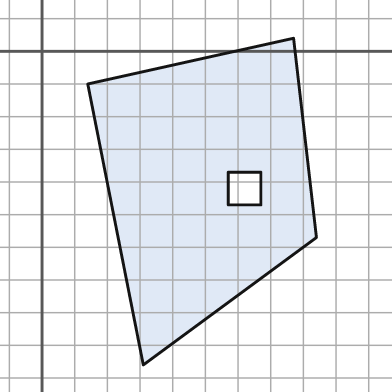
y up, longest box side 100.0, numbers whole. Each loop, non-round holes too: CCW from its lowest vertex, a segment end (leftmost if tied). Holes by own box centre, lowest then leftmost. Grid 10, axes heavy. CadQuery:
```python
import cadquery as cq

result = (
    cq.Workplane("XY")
    .moveTo(31.0, -96.0)
    .lineTo(84.0, -57.0)
    .lineTo(77.0, 4.0)
    .lineTo(14.0, -10.0)
    .close()
    .moveTo(57.0, -47.0)
    .lineTo(67.0, -47.0)
    .lineTo(67.0, -37.0)
    .lineTo(57.0, -37.0)
    .close()
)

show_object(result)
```